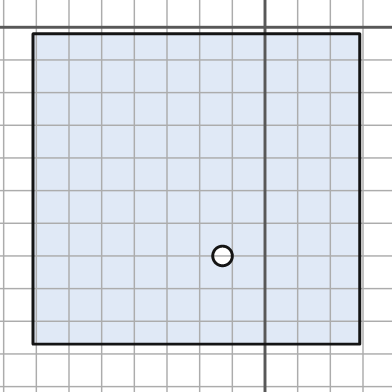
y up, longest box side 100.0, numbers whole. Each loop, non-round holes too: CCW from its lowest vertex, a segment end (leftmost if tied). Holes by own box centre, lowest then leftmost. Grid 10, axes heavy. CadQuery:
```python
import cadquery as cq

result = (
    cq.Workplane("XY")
    .moveTo(-71.0, -97.0)
    .lineTo(29.0, -97.0)
    .lineTo(29.0, -2.0)
    .lineTo(-71.0, -2.0)
    .close()
    .moveTo(-13.0, -70.0)
    .circle(3.0)
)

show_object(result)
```